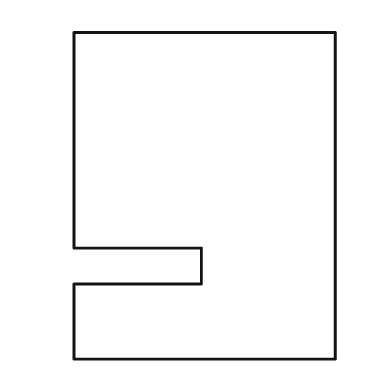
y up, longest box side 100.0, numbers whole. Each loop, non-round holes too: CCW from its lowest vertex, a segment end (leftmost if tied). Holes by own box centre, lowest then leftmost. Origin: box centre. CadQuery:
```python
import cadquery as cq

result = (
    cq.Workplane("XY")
    .moveTo(-40.0, -50.0)
    .lineTo(40.0, -50.0)
    .lineTo(40.0, 50.0)
    .lineTo(-40.0, 50.0)
    .lineTo(-40.0, -16.0)
    .lineTo(-1.0, -16.0)
    .lineTo(-1.0, -27.0)
    .lineTo(-40.0, -27.0)
    .close()
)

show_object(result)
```